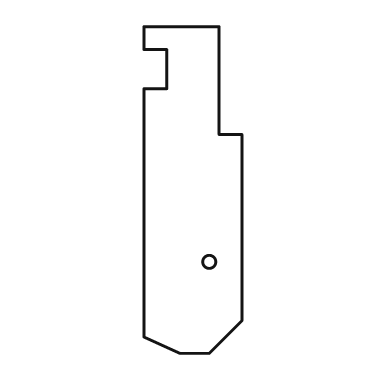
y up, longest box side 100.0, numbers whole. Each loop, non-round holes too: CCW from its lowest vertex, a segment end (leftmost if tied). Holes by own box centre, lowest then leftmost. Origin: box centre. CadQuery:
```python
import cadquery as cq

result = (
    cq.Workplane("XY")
    .moveTo(-4.0, -50.0)
    .lineTo(5.0, -50.0)
    .lineTo(15.0, -40.0)
    .lineTo(15.0, 17.0)
    .lineTo(8.0, 17.0)
    .lineTo(8.0, 50.0)
    .lineTo(-15.0, 50.0)
    .lineTo(-15.0, 43.0)
    .lineTo(-8.0, 43.0)
    .lineTo(-8.0, 31.0)
    .lineTo(-15.0, 31.0)
    .lineTo(-15.0, -45.0)
    .close()
    .moveTo(5.0, -22.0)
    .circle(2.0)
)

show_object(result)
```